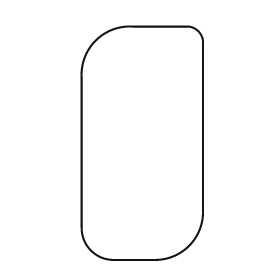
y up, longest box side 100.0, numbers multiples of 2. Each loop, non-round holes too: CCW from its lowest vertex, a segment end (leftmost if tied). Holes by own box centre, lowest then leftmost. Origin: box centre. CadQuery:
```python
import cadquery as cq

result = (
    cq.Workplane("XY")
    .moveTo(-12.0, -50.0)
    .lineTo(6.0, -50.0)
    .threePointArc((20.0, -44.0), (26.0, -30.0))
    .lineTo(26.0, 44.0)
    .threePointArc((24.0, 48.0), (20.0, 50.0))
    .lineTo(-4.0, 50.0)
    .threePointArc((-20.0, 44.0), (-26.0, 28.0))
    .lineTo(-26.0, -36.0)
    .threePointArc((-22.0, -46.0), (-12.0, -50.0))
    .close()
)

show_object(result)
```